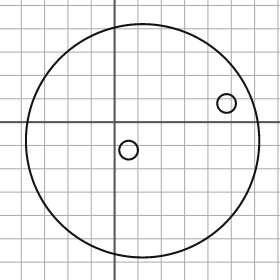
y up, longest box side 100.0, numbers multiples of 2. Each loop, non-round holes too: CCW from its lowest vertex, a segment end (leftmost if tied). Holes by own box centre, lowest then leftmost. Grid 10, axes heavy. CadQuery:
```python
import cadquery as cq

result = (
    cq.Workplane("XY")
    .moveTo(12.0, -8.0)
    .circle(50.0)
    .moveTo(6.0, -12.0)
    .circle(4.0)
    .moveTo(48.0, 8.0)
    .circle(4.0)
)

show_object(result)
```